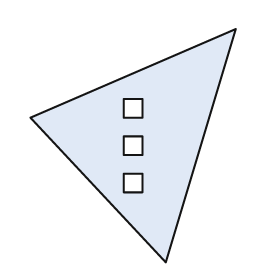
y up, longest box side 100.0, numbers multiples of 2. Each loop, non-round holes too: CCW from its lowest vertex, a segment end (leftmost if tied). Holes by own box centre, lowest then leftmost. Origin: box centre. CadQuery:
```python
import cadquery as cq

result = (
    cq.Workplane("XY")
    .moveTo(14.0, -50.0)
    .lineTo(44.0, 50.0)
    .lineTo(-44.0, 12.0)
    .close()
    .moveTo(-4.0, -20.0)
    .lineTo(4.0, -20.0)
    .lineTo(4.0, -12.0)
    .lineTo(-4.0, -12.0)
    .close()
    .moveTo(-4.0, -4.0)
    .lineTo(4.0, -4.0)
    .lineTo(4.0, 4.0)
    .lineTo(-4.0, 4.0)
    .close()
    .moveTo(-4.0, 12.0)
    .lineTo(4.0, 12.0)
    .lineTo(4.0, 20.0)
    .lineTo(-4.0, 20.0)
    .close()
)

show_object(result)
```